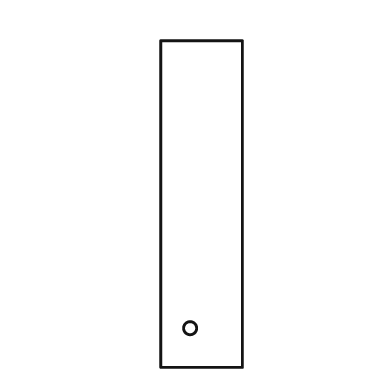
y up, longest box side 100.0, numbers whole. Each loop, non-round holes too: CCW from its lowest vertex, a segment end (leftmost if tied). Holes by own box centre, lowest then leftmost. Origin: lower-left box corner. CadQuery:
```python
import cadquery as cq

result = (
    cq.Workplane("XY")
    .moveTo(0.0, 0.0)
    .lineTo(25.0, 0.0)
    .lineTo(25.0, 100.0)
    .lineTo(0.0, 100.0)
    .close()
    .moveTo(9.0, 12.0)
    .circle(2.0)
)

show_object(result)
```